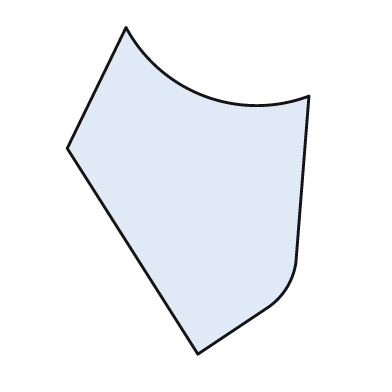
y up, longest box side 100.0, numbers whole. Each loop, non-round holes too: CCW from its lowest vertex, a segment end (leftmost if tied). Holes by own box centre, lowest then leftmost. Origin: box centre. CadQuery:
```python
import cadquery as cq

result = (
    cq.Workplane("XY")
    .moveTo(3.0, -50.0)
    .lineTo(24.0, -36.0)
    .threePointArc((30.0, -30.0), (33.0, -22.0))
    .lineTo(37.0, 29.0)
    .threePointArc((5.0, 29.0), (-19.0, 50.0))
    .lineTo(-37.0, 13.0)
    .close()
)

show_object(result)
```